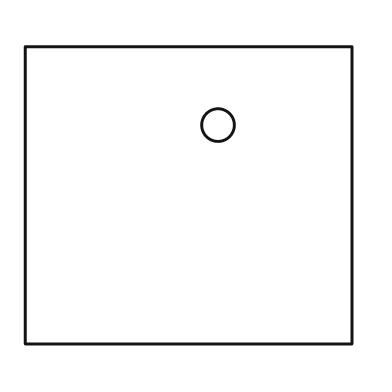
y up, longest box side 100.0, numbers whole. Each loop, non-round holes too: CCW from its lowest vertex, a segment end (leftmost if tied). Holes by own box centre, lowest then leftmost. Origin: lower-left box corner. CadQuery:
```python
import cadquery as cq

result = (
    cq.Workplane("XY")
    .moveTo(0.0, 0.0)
    .lineTo(100.0, 0.0)
    .lineTo(100.0, 91.0)
    .lineTo(0.0, 91.0)
    .close()
    .moveTo(59.0, 67.0)
    .circle(5.0)
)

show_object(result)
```